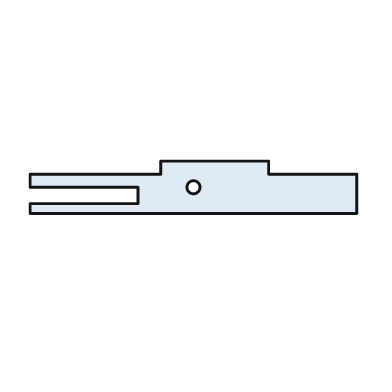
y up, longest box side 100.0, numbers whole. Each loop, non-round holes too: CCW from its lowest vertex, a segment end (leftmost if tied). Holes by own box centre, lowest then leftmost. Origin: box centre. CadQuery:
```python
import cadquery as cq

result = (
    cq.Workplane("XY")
    .moveTo(-50.0, -8.0)
    .lineTo(50.0, -8.0)
    .lineTo(50.0, 4.0)
    .lineTo(23.0, 4.0)
    .lineTo(23.0, 8.0)
    .lineTo(-10.0, 8.0)
    .lineTo(-10.0, 4.0)
    .lineTo(-50.0, 4.0)
    .lineTo(-50.0, 0.0)
    .lineTo(-17.0, 0.0)
    .lineTo(-17.0, -5.0)
    .lineTo(-50.0, -5.0)
    .close()
    .moveTo(0.0, 0.0)
    .circle(2.0)
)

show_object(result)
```